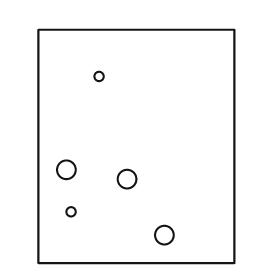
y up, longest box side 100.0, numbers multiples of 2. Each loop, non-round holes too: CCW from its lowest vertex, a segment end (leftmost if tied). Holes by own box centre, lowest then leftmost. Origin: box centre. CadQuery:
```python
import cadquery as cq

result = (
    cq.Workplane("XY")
    .moveTo(-42.0, -50.0)
    .lineTo(42.0, -50.0)
    .lineTo(42.0, 50.0)
    .lineTo(-42.0, 50.0)
    .close()
    .moveTo(12.0, -38.0)
    .circle(4.0)
    .moveTo(-28.0, -28.0)
    .circle(2.0)
    .moveTo(-4.0, -14.0)
    .circle(4.0)
    .moveTo(-30.0, -10.0)
    .circle(4.0)
    .moveTo(-16.0, 30.0)
    .circle(2.0)
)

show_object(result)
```